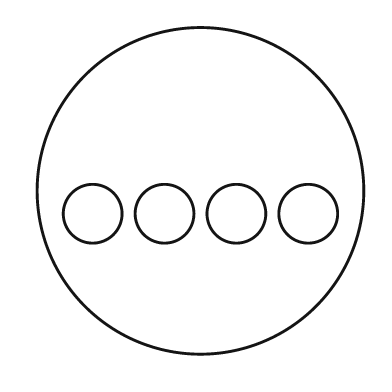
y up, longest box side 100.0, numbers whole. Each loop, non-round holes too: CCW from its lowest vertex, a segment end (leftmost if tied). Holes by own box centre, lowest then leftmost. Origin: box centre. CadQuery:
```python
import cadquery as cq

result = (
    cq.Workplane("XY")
    .moveTo(0.0, 0.0)
    .circle(50.0)
    .moveTo(-33.0, -7.0)
    .circle(9.0)
    .moveTo(-11.0, -7.0)
    .circle(9.0)
    .moveTo(11.0, -7.0)
    .circle(9.0)
    .moveTo(33.0, -7.0)
    .circle(9.0)
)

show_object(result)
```